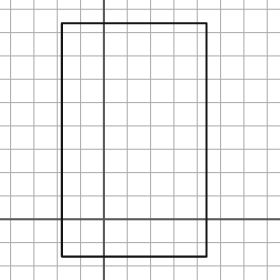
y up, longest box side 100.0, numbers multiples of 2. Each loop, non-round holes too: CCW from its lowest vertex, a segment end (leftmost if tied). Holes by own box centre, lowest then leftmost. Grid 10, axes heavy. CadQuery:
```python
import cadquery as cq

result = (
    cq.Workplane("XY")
    .moveTo(-18.0, -16.0)
    .lineTo(44.0, -16.0)
    .lineTo(44.0, 84.0)
    .lineTo(-18.0, 84.0)
    .close()
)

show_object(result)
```